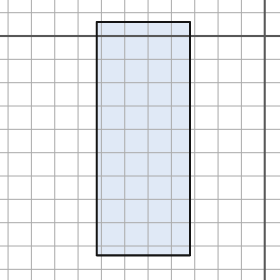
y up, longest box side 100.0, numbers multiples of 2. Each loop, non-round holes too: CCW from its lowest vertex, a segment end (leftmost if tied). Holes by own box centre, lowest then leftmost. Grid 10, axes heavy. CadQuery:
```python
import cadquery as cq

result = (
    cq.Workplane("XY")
    .moveTo(-72.0, -94.0)
    .lineTo(-32.0, -94.0)
    .lineTo(-32.0, 6.0)
    .lineTo(-72.0, 6.0)
    .close()
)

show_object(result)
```